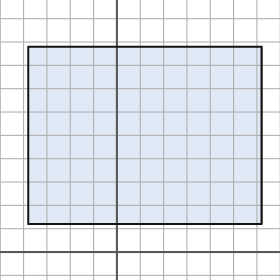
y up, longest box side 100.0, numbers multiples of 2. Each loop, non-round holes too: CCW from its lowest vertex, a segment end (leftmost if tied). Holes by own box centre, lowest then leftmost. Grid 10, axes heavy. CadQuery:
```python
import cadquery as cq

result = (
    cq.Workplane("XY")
    .moveTo(-38.0, 12.0)
    .lineTo(62.0, 12.0)
    .lineTo(62.0, 88.0)
    .lineTo(-38.0, 88.0)
    .close()
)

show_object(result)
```